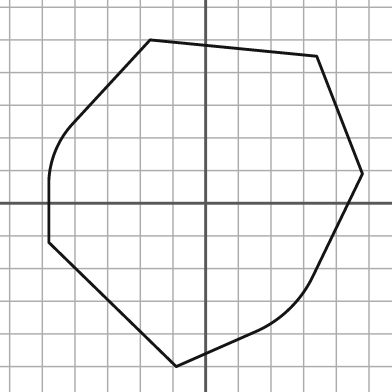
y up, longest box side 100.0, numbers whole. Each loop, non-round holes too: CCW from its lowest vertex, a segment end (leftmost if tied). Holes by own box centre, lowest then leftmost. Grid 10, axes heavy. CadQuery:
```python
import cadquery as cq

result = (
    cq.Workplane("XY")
    .moveTo(-9.0, -50.0)
    .lineTo(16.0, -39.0)
    .threePointArc((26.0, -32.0), (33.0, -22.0))
    .lineTo(48.0, 9.0)
    .lineTo(34.0, 45.0)
    .lineTo(-17.0, 50.0)
    .lineTo(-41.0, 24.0)
    .threePointArc((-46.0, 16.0), (-48.0, 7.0))
    .lineTo(-48.0, -12.0)
    .close()
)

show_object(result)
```